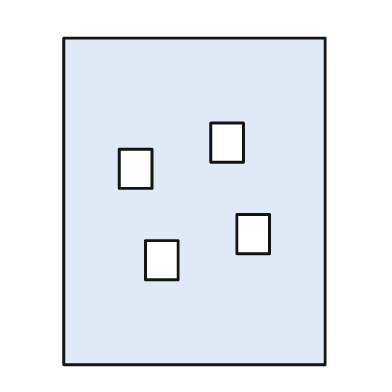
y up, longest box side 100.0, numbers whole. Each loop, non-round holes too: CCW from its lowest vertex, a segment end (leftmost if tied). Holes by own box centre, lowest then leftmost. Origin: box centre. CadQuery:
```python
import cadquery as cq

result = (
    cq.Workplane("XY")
    .moveTo(-40.0, -50.0)
    .lineTo(40.0, -50.0)
    .lineTo(40.0, 50.0)
    .lineTo(-40.0, 50.0)
    .close()
    .moveTo(-15.0, -24.0)
    .lineTo(-5.0, -24.0)
    .lineTo(-5.0, -12.0)
    .lineTo(-15.0, -12.0)
    .close()
    .moveTo(13.0, -16.0)
    .lineTo(23.0, -16.0)
    .lineTo(23.0, -4.0)
    .lineTo(13.0, -4.0)
    .close()
    .moveTo(-23.0, 4.0)
    .lineTo(-13.0, 4.0)
    .lineTo(-13.0, 16.0)
    .lineTo(-23.0, 16.0)
    .close()
    .moveTo(5.0, 12.0)
    .lineTo(15.0, 12.0)
    .lineTo(15.0, 24.0)
    .lineTo(5.0, 24.0)
    .close()
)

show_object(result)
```